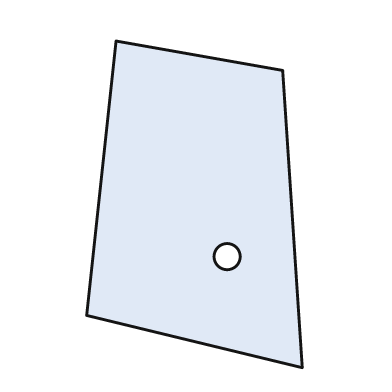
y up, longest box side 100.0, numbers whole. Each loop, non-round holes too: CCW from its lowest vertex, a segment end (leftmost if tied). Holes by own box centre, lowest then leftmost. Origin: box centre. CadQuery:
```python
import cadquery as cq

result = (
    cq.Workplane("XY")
    .moveTo(33.0, -50.0)
    .lineTo(27.0, 41.0)
    .lineTo(-24.0, 50.0)
    .lineTo(-33.0, -34.0)
    .close()
    .moveTo(10.0, -16.0)
    .circle(4.0)
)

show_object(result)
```